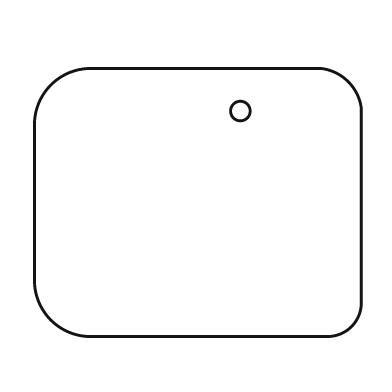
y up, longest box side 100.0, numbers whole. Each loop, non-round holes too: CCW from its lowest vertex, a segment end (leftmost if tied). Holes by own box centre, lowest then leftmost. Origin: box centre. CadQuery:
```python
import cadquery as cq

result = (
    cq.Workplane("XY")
    .moveTo(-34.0, -41.0)
    .lineTo(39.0, -41.0)
    .threePointArc((47.0, -38.0), (50.0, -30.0))
    .lineTo(50.0, 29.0)
    .threePointArc((46.0, 37.0), (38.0, 41.0))
    .lineTo(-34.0, 41.0)
    .threePointArc((-45.0, 36.0), (-50.0, 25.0))
    .lineTo(-50.0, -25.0)
    .threePointArc((-45.0, -36.0), (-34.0, -41.0))
    .close()
    .moveTo(13.0, 28.0)
    .circle(3.0)
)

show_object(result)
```